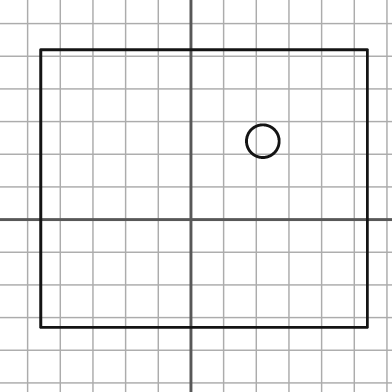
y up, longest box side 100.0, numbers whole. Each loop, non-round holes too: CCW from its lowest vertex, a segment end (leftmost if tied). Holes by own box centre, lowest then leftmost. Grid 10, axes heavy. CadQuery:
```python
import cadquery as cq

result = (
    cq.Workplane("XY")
    .moveTo(-46.0, -33.0)
    .lineTo(54.0, -33.0)
    .lineTo(54.0, 52.0)
    .lineTo(-46.0, 52.0)
    .close()
    .moveTo(22.0, 24.0)
    .circle(5.0)
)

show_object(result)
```